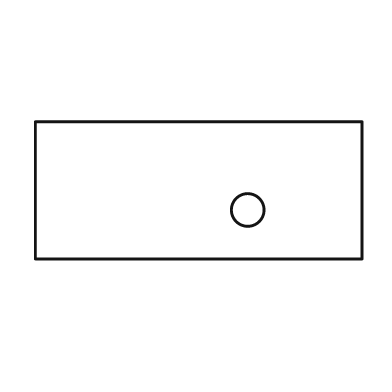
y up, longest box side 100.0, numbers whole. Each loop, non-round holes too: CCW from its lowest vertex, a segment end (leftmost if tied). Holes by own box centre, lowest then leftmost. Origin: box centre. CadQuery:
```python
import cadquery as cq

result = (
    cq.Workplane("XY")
    .moveTo(-50.0, -21.0)
    .lineTo(50.0, -21.0)
    .lineTo(50.0, 21.0)
    .lineTo(-50.0, 21.0)
    .close()
    .moveTo(15.0, -6.0)
    .circle(5.0)
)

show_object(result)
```